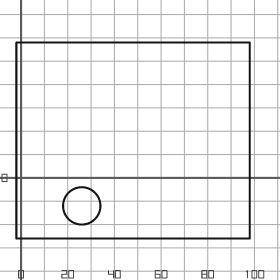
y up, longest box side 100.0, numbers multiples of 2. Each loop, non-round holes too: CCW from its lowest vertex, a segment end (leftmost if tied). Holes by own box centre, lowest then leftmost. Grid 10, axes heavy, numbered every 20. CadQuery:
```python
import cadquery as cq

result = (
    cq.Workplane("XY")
    .moveTo(-2.0, -26.0)
    .lineTo(98.0, -26.0)
    .lineTo(98.0, 58.0)
    .lineTo(-2.0, 58.0)
    .close()
    .moveTo(26.0, -12.0)
    .circle(8.0)
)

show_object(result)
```